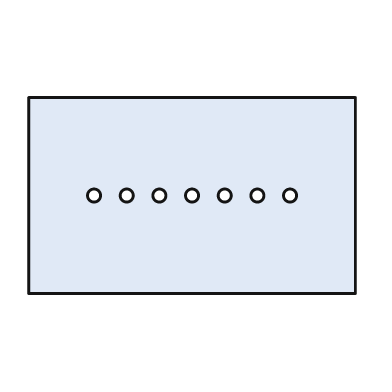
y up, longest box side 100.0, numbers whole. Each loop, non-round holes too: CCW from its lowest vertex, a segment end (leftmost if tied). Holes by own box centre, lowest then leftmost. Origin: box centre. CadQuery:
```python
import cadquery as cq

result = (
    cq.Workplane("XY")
    .moveTo(-50.0, -30.0)
    .lineTo(50.0, -30.0)
    .lineTo(50.0, 30.0)
    .lineTo(-50.0, 30.0)
    .close()
    .moveTo(-30.0, 0.0)
    .circle(2.0)
    .moveTo(-20.0, 0.0)
    .circle(2.0)
    .moveTo(-10.0, 0.0)
    .circle(2.0)
    .moveTo(0.0, 0.0)
    .circle(2.0)
    .moveTo(10.0, 0.0)
    .circle(2.0)
    .moveTo(20.0, 0.0)
    .circle(2.0)
    .moveTo(30.0, 0.0)
    .circle(2.0)
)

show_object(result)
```